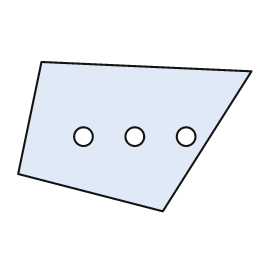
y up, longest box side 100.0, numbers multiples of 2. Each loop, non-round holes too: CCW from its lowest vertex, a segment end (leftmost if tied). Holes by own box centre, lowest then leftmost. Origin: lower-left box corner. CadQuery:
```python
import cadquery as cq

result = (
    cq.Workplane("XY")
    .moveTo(62.0, 0.0)
    .lineTo(100.0, 60.0)
    .lineTo(10.0, 64.0)
    .lineTo(0.0, 16.0)
    .close()
    .moveTo(28.0, 32.0)
    .circle(4.0)
    .moveTo(50.0, 32.0)
    .circle(4.0)
    .moveTo(72.0, 32.0)
    .circle(4.0)
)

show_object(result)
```